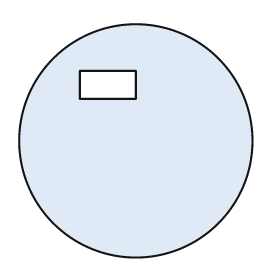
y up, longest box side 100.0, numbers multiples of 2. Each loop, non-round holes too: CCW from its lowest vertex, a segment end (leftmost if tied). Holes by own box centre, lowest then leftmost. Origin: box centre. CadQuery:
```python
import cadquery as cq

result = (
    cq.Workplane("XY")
    .moveTo(0.0, 0.0)
    .circle(50.0)
    .moveTo(-24.0, 18.0)
    .lineTo(0.0, 18.0)
    .lineTo(0.0, 30.0)
    .lineTo(-24.0, 30.0)
    .close()
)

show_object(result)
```